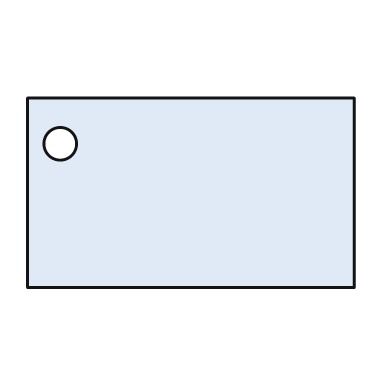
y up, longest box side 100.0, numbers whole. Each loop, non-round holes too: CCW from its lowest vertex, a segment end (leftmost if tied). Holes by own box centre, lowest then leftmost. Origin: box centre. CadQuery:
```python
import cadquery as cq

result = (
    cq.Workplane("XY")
    .moveTo(-50.0, -29.0)
    .lineTo(50.0, -29.0)
    .lineTo(50.0, 29.0)
    .lineTo(-50.0, 29.0)
    .close()
    .moveTo(-40.0, 15.0)
    .circle(5.0)
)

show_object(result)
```